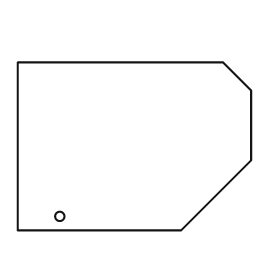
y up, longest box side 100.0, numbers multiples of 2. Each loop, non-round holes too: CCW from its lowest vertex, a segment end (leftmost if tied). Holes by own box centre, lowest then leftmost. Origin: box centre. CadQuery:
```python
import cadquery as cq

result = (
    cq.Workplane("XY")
    .moveTo(-50.0, -36.0)
    .lineTo(20.0, -36.0)
    .lineTo(50.0, -6.0)
    .lineTo(50.0, 24.0)
    .lineTo(38.0, 36.0)
    .lineTo(-50.0, 36.0)
    .close()
    .moveTo(-32.0, -30.0)
    .circle(2.0)
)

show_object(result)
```